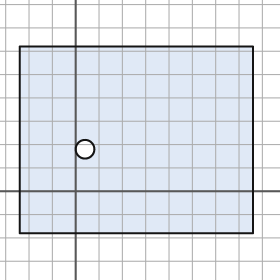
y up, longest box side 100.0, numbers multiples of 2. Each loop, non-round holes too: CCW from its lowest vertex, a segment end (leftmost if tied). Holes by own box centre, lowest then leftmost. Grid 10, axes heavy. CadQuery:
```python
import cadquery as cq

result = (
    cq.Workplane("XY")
    .moveTo(-24.0, -18.0)
    .lineTo(76.0, -18.0)
    .lineTo(76.0, 62.0)
    .lineTo(-24.0, 62.0)
    .close()
    .moveTo(4.0, 18.0)
    .circle(4.0)
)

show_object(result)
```